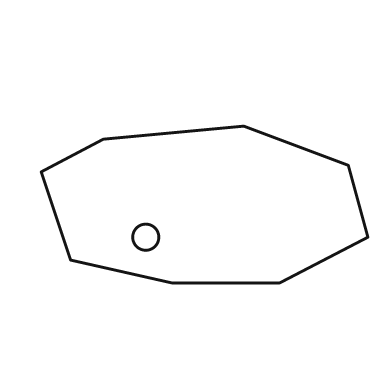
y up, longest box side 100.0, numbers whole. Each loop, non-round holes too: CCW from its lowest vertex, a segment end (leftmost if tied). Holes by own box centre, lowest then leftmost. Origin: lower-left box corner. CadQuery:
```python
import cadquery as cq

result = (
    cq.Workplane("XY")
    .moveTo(40.0, 0.0)
    .lineTo(73.0, 0.0)
    .lineTo(100.0, 14.0)
    .lineTo(94.0, 36.0)
    .lineTo(62.0, 48.0)
    .lineTo(19.0, 44.0)
    .lineTo(0.0, 34.0)
    .lineTo(9.0, 7.0)
    .close()
    .moveTo(32.0, 14.0)
    .circle(4.0)
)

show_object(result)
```